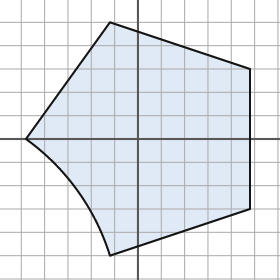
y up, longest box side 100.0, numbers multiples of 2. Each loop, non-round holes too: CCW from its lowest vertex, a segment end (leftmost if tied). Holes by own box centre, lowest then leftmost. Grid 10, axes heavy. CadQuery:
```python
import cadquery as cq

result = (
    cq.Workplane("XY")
    .moveTo(-12.0, -50.0)
    .lineTo(48.0, -30.0)
    .lineTo(48.0, 30.0)
    .lineTo(-12.0, 50.0)
    .lineTo(-48.0, 0.0)
    .threePointArc((-26.0, -22.0), (-12.0, -50.0))
    .close()
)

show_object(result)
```